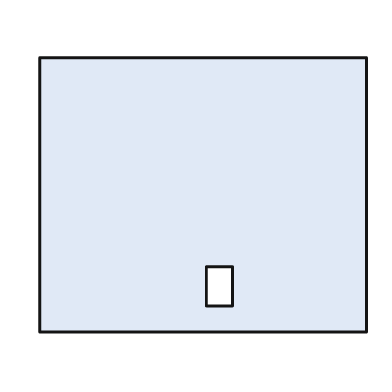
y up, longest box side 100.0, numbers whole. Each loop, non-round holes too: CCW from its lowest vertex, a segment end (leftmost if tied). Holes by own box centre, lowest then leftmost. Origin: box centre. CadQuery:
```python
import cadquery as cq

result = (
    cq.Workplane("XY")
    .moveTo(-50.0, -42.0)
    .lineTo(50.0, -42.0)
    .lineTo(50.0, 42.0)
    .lineTo(-50.0, 42.0)
    .close()
    .moveTo(1.0, -34.0)
    .lineTo(9.0, -34.0)
    .lineTo(9.0, -22.0)
    .lineTo(1.0, -22.0)
    .close()
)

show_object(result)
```